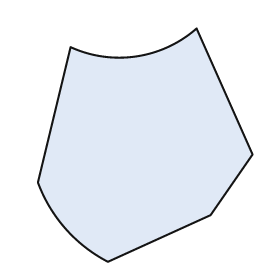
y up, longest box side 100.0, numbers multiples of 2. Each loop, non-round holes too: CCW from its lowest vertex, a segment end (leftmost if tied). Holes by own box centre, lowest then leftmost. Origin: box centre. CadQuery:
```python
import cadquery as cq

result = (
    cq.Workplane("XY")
    .moveTo(-16.0, -50.0)
    .lineTo(28.0, -30.0)
    .lineTo(46.0, -4.0)
    .lineTo(22.0, 50.0)
    .threePointArc((-4.0, 38.0), (-32.0, 42.0))
    .lineTo(-46.0, -16.0)
    .threePointArc((-34.0, -36.0), (-16.0, -50.0))
    .close()
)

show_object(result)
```